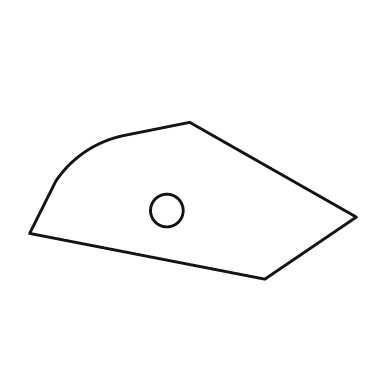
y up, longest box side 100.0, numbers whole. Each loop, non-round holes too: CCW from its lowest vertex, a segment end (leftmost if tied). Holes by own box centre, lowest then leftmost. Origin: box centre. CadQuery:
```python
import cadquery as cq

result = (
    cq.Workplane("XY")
    .moveTo(22.0, -24.0)
    .lineTo(50.0, -5.0)
    .lineTo(-1.0, 24.0)
    .lineTo(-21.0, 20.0)
    .threePointArc((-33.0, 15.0), (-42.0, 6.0))
    .lineTo(-50.0, -10.0)
    .close()
    .moveTo(-8.0, -3.0)
    .circle(5.0)
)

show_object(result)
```